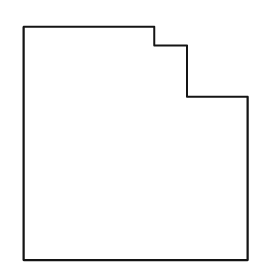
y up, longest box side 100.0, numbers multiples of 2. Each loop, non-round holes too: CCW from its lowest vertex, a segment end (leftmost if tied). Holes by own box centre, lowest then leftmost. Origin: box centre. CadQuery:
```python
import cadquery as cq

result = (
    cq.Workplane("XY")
    .moveTo(-48.0, -50.0)
    .lineTo(48.0, -50.0)
    .lineTo(48.0, 20.0)
    .lineTo(22.0, 20.0)
    .lineTo(22.0, 42.0)
    .lineTo(8.0, 42.0)
    .lineTo(8.0, 50.0)
    .lineTo(-48.0, 50.0)
    .close()
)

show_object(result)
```